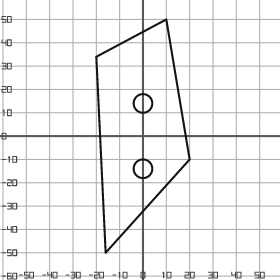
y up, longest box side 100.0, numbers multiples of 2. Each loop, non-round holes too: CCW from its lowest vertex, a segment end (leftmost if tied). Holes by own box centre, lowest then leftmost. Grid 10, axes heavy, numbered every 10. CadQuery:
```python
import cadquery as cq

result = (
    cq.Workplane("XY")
    .moveTo(-16.0, -50.0)
    .lineTo(20.0, -10.0)
    .lineTo(10.0, 50.0)
    .lineTo(-20.0, 34.0)
    .close()
    .moveTo(0.0, -14.0)
    .circle(4.0)
    .moveTo(0.0, 14.0)
    .circle(4.0)
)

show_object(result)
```